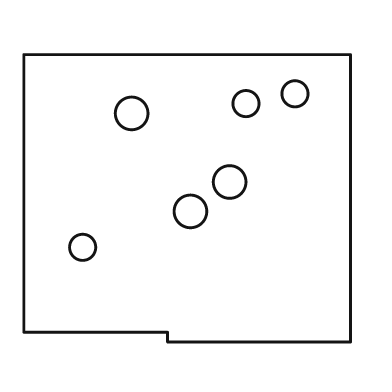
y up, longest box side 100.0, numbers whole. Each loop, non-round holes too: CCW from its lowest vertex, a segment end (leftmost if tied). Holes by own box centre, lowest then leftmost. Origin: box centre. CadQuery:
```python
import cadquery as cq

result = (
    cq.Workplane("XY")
    .moveTo(-6.0, -44.0)
    .lineTo(50.0, -44.0)
    .lineTo(50.0, 44.0)
    .lineTo(-50.0, 44.0)
    .lineTo(-50.0, -41.0)
    .lineTo(-6.0, -41.0)
    .close()
    .moveTo(-32.0, -15.0)
    .circle(4.0)
    .moveTo(1.0, -4.0)
    .circle(5.0)
    .moveTo(13.0, 5.0)
    .circle(5.0)
    .moveTo(-17.0, 26.0)
    .circle(5.0)
    .moveTo(18.0, 29.0)
    .circle(4.0)
    .moveTo(33.0, 32.0)
    .circle(4.0)
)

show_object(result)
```